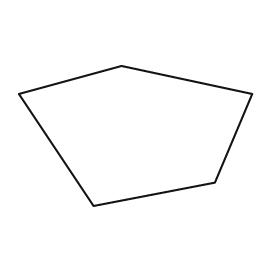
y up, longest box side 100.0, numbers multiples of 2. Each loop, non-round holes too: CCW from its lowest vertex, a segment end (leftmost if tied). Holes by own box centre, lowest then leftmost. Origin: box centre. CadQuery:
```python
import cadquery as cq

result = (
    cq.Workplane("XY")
    .moveTo(-18.0, -30.0)
    .lineTo(34.0, -20.0)
    .lineTo(50.0, 18.0)
    .lineTo(-6.0, 30.0)
    .lineTo(-50.0, 18.0)
    .close()
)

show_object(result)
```